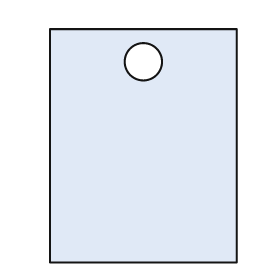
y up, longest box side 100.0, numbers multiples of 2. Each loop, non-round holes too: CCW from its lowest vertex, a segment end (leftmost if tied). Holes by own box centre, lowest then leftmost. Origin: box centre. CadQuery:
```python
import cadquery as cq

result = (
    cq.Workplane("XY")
    .moveTo(-40.0, -50.0)
    .lineTo(40.0, -50.0)
    .lineTo(40.0, 50.0)
    .lineTo(-40.0, 50.0)
    .close()
    .moveTo(0.0, 36.0)
    .circle(8.0)
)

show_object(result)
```